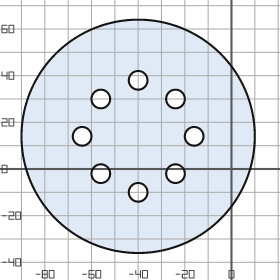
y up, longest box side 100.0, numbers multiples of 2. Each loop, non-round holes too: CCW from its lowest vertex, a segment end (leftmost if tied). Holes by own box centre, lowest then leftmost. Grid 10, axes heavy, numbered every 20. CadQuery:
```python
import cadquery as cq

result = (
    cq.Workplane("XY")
    .moveTo(-40.0, 14.0)
    .circle(50.0)
    .moveTo(-40.0, -10.0)
    .circle(4.0)
    .moveTo(-56.0, -2.0)
    .circle(4.0)
    .moveTo(-24.0, -2.0)
    .circle(4.0)
    .moveTo(-64.0, 14.0)
    .circle(4.0)
    .moveTo(-16.0, 14.0)
    .circle(4.0)
    .moveTo(-56.0, 30.0)
    .circle(4.0)
    .moveTo(-24.0, 30.0)
    .circle(4.0)
    .moveTo(-40.0, 38.0)
    .circle(4.0)
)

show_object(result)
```